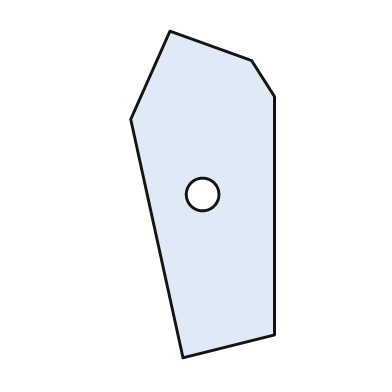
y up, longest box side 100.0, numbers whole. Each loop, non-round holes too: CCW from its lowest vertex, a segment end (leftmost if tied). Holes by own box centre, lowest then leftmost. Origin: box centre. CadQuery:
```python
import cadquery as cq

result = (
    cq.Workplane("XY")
    .moveTo(-6.0, -50.0)
    .lineTo(22.0, -43.0)
    .lineTo(22.0, 30.0)
    .lineTo(15.0, 41.0)
    .lineTo(-10.0, 50.0)
    .lineTo(-22.0, 23.0)
    .close()
    .moveTo(0.0, 0.0)
    .circle(5.0)
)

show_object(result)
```